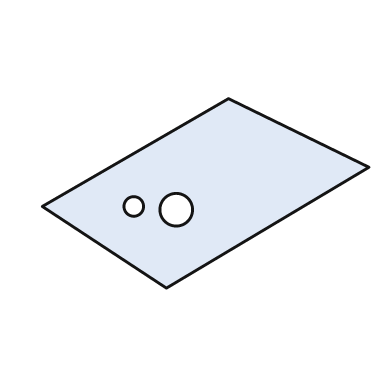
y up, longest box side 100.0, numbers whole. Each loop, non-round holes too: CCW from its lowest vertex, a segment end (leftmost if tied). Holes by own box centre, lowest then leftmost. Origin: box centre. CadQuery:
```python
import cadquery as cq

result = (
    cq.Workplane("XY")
    .moveTo(-12.0, -29.0)
    .lineTo(50.0, 8.0)
    .lineTo(7.0, 29.0)
    .lineTo(-50.0, -4.0)
    .close()
    .moveTo(-9.0, -5.0)
    .circle(5.0)
    .moveTo(-22.0, -4.0)
    .circle(3.0)
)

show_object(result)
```